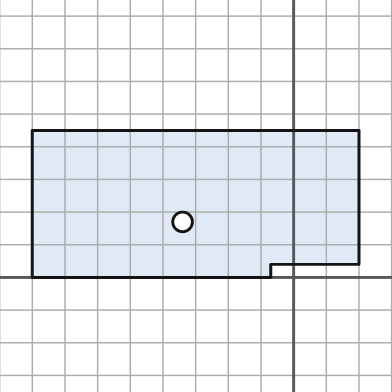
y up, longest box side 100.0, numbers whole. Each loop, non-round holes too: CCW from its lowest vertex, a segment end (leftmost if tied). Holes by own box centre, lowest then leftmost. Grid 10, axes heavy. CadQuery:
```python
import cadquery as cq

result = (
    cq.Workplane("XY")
    .moveTo(-80.0, 0.0)
    .lineTo(-7.0, 0.0)
    .lineTo(-7.0, 4.0)
    .lineTo(20.0, 4.0)
    .lineTo(20.0, 45.0)
    .lineTo(-80.0, 45.0)
    .close()
    .moveTo(-34.0, 17.0)
    .circle(3.0)
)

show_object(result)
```